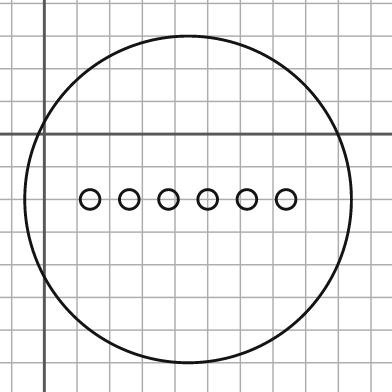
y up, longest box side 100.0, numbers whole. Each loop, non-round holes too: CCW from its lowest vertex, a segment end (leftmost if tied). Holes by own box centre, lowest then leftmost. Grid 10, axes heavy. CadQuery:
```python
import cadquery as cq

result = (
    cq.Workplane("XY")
    .moveTo(44.0, -20.0)
    .circle(50.0)
    .moveTo(14.0, -20.0)
    .circle(3.0)
    .moveTo(26.0, -20.0)
    .circle(3.0)
    .moveTo(38.0, -20.0)
    .circle(3.0)
    .moveTo(50.0, -20.0)
    .circle(3.0)
    .moveTo(62.0, -20.0)
    .circle(3.0)
    .moveTo(74.0, -20.0)
    .circle(3.0)
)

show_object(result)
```